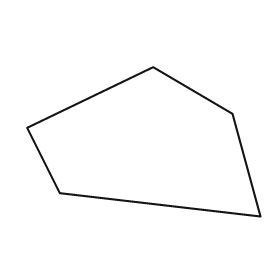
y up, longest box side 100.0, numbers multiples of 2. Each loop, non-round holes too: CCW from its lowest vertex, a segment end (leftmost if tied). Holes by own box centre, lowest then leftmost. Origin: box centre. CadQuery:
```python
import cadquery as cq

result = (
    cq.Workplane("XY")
    .moveTo(50.0, -32.0)
    .lineTo(38.0, 12.0)
    .lineTo(4.0, 32.0)
    .lineTo(-50.0, 6.0)
    .lineTo(-36.0, -22.0)
    .close()
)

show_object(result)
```